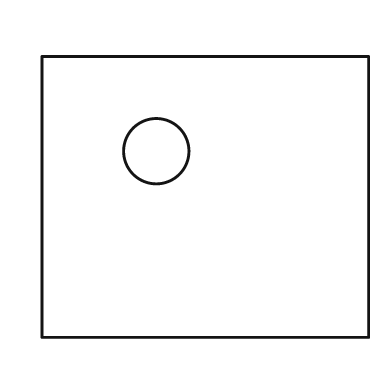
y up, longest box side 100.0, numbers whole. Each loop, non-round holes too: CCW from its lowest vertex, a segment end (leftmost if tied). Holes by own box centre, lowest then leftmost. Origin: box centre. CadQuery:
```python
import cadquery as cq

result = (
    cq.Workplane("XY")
    .moveTo(-50.0, -43.0)
    .lineTo(50.0, -43.0)
    .lineTo(50.0, 43.0)
    .lineTo(-50.0, 43.0)
    .close()
    .moveTo(-15.0, 14.0)
    .circle(10.0)
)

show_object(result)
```